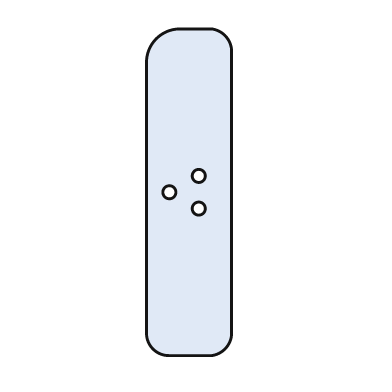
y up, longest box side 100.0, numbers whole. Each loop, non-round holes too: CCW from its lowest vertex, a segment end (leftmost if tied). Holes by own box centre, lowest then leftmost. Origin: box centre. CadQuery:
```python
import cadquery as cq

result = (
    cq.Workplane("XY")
    .moveTo(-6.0, -50.0)
    .lineTo(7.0, -50.0)
    .threePointArc((11.0, -48.0), (13.0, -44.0))
    .lineTo(13.0, 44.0)
    .threePointArc((11.0, 48.0), (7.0, 50.0))
    .lineTo(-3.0, 50.0)
    .threePointArc((-10.0, 47.0), (-13.0, 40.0))
    .lineTo(-13.0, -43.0)
    .threePointArc((-11.0, -48.0), (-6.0, -50.0))
    .close()
    .moveTo(3.0, -5.0)
    .circle(2.0)
    .moveTo(-6.0, 0.0)
    .circle(2.0)
    .moveTo(3.0, 5.0)
    .circle(2.0)
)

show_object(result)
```